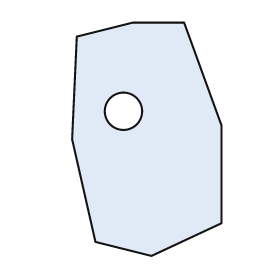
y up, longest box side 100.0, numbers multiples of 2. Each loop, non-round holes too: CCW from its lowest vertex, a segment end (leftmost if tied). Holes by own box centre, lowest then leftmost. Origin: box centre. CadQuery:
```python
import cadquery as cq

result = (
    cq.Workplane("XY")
    .moveTo(2.0, -50.0)
    .lineTo(32.0, -36.0)
    .lineTo(32.0, 6.0)
    .lineTo(16.0, 50.0)
    .lineTo(-6.0, 50.0)
    .lineTo(-30.0, 44.0)
    .lineTo(-32.0, 0.0)
    .lineTo(-22.0, -44.0)
    .close()
    .moveTo(-10.0, 12.0)
    .circle(8.0)
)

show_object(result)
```